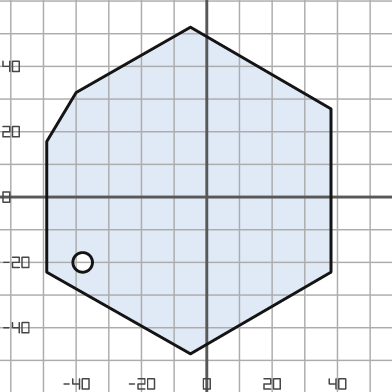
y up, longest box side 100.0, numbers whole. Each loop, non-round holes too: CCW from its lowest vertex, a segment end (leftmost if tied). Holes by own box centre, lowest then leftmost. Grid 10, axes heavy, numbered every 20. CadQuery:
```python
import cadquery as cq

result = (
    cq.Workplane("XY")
    .moveTo(-5.0, -48.0)
    .lineTo(38.0, -23.0)
    .lineTo(38.0, 27.0)
    .lineTo(-5.0, 52.0)
    .lineTo(-40.0, 32.0)
    .lineTo(-49.0, 17.0)
    .lineTo(-49.0, -23.0)
    .close()
    .moveTo(-38.0, -20.0)
    .circle(3.0)
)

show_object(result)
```